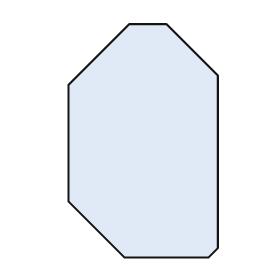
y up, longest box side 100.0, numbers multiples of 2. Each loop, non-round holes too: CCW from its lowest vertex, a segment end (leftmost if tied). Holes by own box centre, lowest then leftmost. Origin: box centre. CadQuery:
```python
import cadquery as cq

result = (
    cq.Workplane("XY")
    .moveTo(-8.0, -50.0)
    .lineTo(28.0, -50.0)
    .lineTo(32.0, -46.0)
    .lineTo(32.0, 28.0)
    .lineTo(10.0, 50.0)
    .lineTo(-6.0, 50.0)
    .lineTo(-32.0, 24.0)
    .lineTo(-32.0, -26.0)
    .close()
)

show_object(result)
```